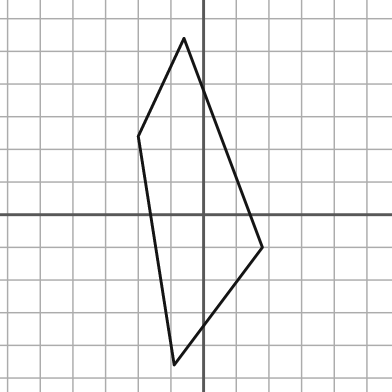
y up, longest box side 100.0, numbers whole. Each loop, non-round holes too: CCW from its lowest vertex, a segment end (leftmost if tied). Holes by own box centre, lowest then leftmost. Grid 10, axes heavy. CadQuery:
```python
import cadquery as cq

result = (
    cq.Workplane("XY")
    .moveTo(-9.0, -46.0)
    .lineTo(18.0, -10.0)
    .lineTo(-6.0, 54.0)
    .lineTo(-20.0, 24.0)
    .close()
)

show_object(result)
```